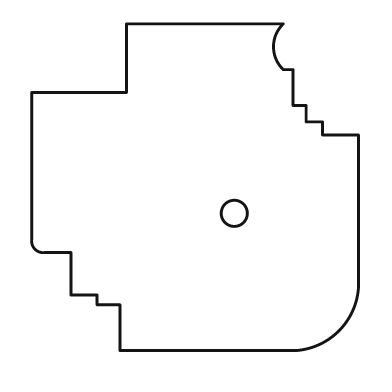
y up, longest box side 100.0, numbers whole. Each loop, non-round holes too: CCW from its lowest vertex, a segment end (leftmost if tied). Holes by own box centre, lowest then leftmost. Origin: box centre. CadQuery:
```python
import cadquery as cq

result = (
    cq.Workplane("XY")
    .moveTo(-23.0, -50.0)
    .lineTo(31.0, -50.0)
    .threePointArc((44.0, -44.0), (50.0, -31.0))
    .lineTo(50.0, 16.0)
    .lineTo(39.0, 16.0)
    .lineTo(39.0, 20.0)
    .lineTo(34.0, 20.0)
    .lineTo(34.0, 25.0)
    .lineTo(30.0, 25.0)
    .lineTo(30.0, 36.0)
    .lineTo(27.0, 36.0)
    .threePointArc((24.0, 43.0), (27.0, 50.0))
    .lineTo(-21.0, 50.0)
    .lineTo(-21.0, 29.0)
    .lineTo(-50.0, 29.0)
    .lineTo(-50.0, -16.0)
    .threePointArc((-49.0, -19.0), (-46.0, -20.0))
    .lineTo(-38.0, -20.0)
    .lineTo(-38.0, -33.0)
    .lineTo(-30.0, -33.0)
    .lineTo(-30.0, -36.0)
    .lineTo(-23.0, -36.0)
    .close()
    .moveTo(12.0, -8.0)
    .circle(4.0)
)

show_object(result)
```